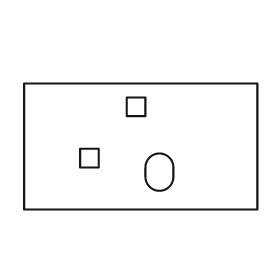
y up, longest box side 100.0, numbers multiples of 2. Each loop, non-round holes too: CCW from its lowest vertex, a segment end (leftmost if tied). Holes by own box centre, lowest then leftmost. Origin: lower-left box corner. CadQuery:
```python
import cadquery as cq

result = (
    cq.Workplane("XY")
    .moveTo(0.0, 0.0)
    .lineTo(100.0, 0.0)
    .lineTo(100.0, 54.0)
    .lineTo(0.0, 54.0)
    .close()
    .moveTo(52.0, 14.0)
    .threePointArc((58.0, 8.0), (64.0, 14.0))
    .lineTo(64.0, 18.0)
    .threePointArc((58.0, 24.0), (52.0, 18.0))
    .close()
    .moveTo(24.0, 18.0)
    .lineTo(32.0, 18.0)
    .lineTo(32.0, 26.0)
    .lineTo(24.0, 26.0)
    .close()
    .moveTo(44.0, 40.0)
    .lineTo(52.0, 40.0)
    .lineTo(52.0, 48.0)
    .lineTo(44.0, 48.0)
    .close()
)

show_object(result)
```